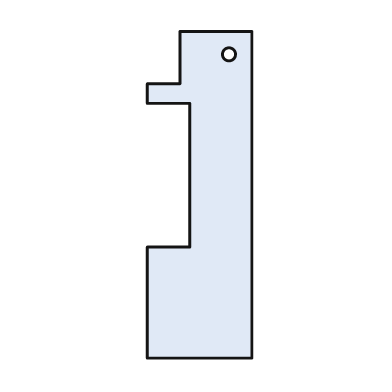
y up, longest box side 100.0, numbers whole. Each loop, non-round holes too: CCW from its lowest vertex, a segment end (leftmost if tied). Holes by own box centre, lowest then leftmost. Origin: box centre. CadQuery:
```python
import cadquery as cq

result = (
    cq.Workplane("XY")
    .moveTo(-16.0, -50.0)
    .lineTo(16.0, -50.0)
    .lineTo(16.0, 50.0)
    .lineTo(-6.0, 50.0)
    .lineTo(-6.0, 34.0)
    .lineTo(-16.0, 34.0)
    .lineTo(-16.0, 28.0)
    .lineTo(-3.0, 28.0)
    .lineTo(-3.0, -16.0)
    .lineTo(-16.0, -16.0)
    .close()
    .moveTo(9.0, 43.0)
    .circle(2.0)
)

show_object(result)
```